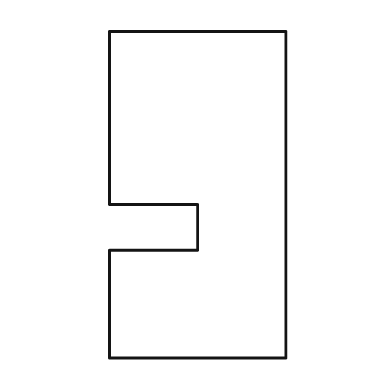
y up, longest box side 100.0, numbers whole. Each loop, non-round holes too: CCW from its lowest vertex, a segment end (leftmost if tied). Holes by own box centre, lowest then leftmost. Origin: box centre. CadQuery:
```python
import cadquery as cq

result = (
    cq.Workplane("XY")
    .moveTo(-27.0, -50.0)
    .lineTo(27.0, -50.0)
    .lineTo(27.0, 50.0)
    .lineTo(-27.0, 50.0)
    .lineTo(-27.0, -3.0)
    .lineTo(0.0, -3.0)
    .lineTo(0.0, -17.0)
    .lineTo(-27.0, -17.0)
    .close()
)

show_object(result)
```